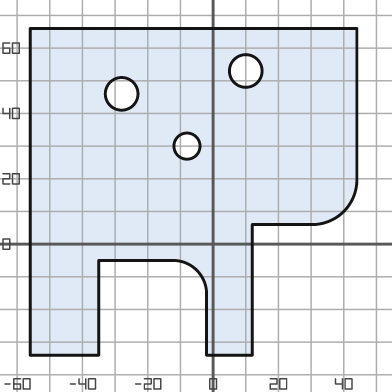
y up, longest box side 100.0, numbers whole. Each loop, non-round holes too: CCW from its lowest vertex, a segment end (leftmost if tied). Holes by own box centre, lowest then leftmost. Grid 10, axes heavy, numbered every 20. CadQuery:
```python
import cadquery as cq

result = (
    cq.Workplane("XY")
    .moveTo(-56.0, -34.0)
    .lineTo(-35.0, -34.0)
    .lineTo(-35.0, -5.0)
    .lineTo(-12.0, -5.0)
    .threePointArc((-5.0, -8.0), (-2.0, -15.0))
    .lineTo(-2.0, -34.0)
    .lineTo(12.0, -34.0)
    .lineTo(12.0, 6.0)
    .lineTo(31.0, 6.0)
    .threePointArc((40.0, 10.0), (44.0, 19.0))
    .lineTo(44.0, 66.0)
    .lineTo(-56.0, 66.0)
    .close()
    .moveTo(-8.0, 30.0)
    .circle(4.0)
    .moveTo(-28.0, 46.0)
    .circle(5.0)
    .moveTo(10.0, 53.0)
    .circle(5.0)
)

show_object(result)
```